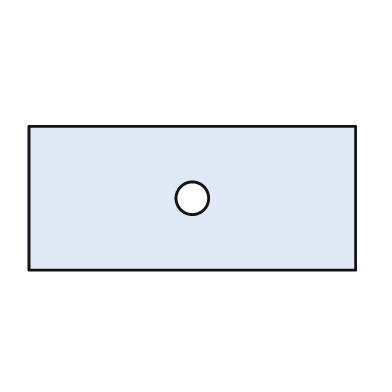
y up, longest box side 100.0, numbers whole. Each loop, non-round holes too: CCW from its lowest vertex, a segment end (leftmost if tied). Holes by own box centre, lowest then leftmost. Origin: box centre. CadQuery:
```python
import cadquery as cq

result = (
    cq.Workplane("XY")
    .moveTo(-50.0, -22.0)
    .lineTo(50.0, -22.0)
    .lineTo(50.0, 22.0)
    .lineTo(-50.0, 22.0)
    .close()
    .moveTo(0.0, 0.0)
    .circle(5.0)
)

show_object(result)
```